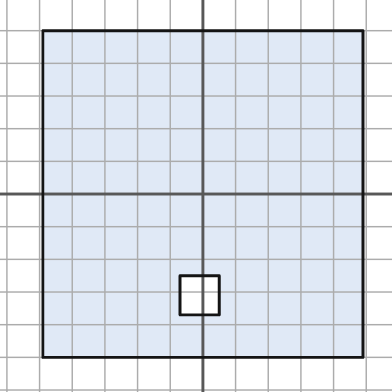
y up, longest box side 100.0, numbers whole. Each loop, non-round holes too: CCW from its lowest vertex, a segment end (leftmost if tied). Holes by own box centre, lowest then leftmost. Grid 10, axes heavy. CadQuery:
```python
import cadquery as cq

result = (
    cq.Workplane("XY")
    .moveTo(-49.0, -50.0)
    .lineTo(49.0, -50.0)
    .lineTo(49.0, 50.0)
    .lineTo(-49.0, 50.0)
    .close()
    .moveTo(-7.0, -37.0)
    .lineTo(5.0, -37.0)
    .lineTo(5.0, -25.0)
    .lineTo(-7.0, -25.0)
    .close()
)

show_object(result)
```